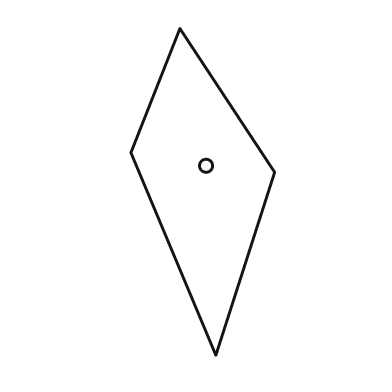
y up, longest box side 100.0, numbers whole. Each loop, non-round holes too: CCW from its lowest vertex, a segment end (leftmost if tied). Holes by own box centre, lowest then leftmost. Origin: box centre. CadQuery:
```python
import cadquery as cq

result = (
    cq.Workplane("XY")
    .moveTo(4.0, -50.0)
    .lineTo(22.0, 6.0)
    .lineTo(-7.0, 50.0)
    .lineTo(-22.0, 12.0)
    .close()
    .moveTo(1.0, 8.0)
    .circle(2.0)
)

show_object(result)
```